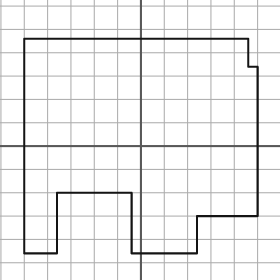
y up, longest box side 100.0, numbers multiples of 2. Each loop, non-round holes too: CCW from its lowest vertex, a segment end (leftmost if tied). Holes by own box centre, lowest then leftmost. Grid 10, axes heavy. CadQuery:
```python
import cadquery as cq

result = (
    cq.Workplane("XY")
    .moveTo(-50.0, -46.0)
    .lineTo(-36.0, -46.0)
    .lineTo(-36.0, -20.0)
    .lineTo(-4.0, -20.0)
    .lineTo(-4.0, -46.0)
    .lineTo(24.0, -46.0)
    .lineTo(24.0, -30.0)
    .lineTo(50.0, -30.0)
    .lineTo(50.0, 34.0)
    .lineTo(46.0, 34.0)
    .lineTo(46.0, 46.0)
    .lineTo(-50.0, 46.0)
    .close()
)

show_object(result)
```